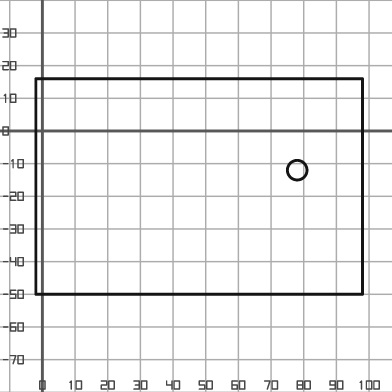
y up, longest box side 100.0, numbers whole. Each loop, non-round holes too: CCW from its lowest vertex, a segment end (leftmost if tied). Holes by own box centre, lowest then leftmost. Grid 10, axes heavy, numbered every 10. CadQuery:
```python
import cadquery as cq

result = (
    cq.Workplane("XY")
    .moveTo(-2.0, -50.0)
    .lineTo(98.0, -50.0)
    .lineTo(98.0, 16.0)
    .lineTo(-2.0, 16.0)
    .close()
    .moveTo(78.0, -12.0)
    .circle(3.0)
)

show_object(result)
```